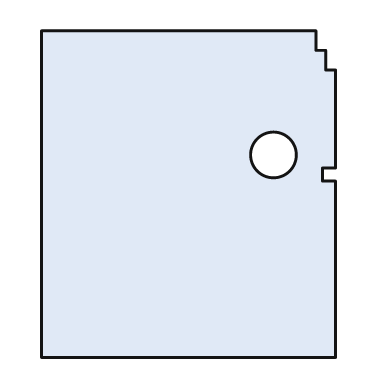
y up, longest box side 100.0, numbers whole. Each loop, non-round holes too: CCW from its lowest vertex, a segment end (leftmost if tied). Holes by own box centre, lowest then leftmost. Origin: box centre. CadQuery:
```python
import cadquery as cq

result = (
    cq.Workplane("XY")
    .moveTo(-45.0, -50.0)
    .lineTo(45.0, -50.0)
    .lineTo(45.0, 4.0)
    .lineTo(41.0, 4.0)
    .lineTo(41.0, 8.0)
    .lineTo(45.0, 8.0)
    .lineTo(45.0, 38.0)
    .lineTo(42.0, 38.0)
    .lineTo(42.0, 44.0)
    .lineTo(39.0, 44.0)
    .lineTo(39.0, 50.0)
    .lineTo(-45.0, 50.0)
    .close()
    .moveTo(26.0, 12.0)
    .circle(7.0)
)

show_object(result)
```